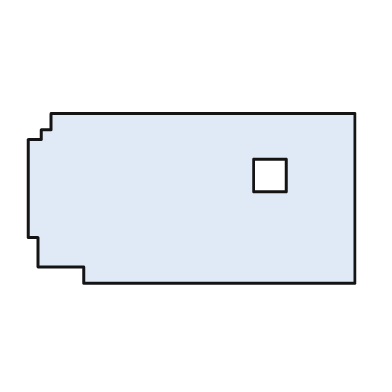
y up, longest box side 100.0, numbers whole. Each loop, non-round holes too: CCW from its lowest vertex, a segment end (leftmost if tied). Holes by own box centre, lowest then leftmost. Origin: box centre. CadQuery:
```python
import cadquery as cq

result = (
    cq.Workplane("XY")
    .moveTo(-33.0, -26.0)
    .lineTo(50.0, -26.0)
    .lineTo(50.0, 26.0)
    .lineTo(-43.0, 26.0)
    .lineTo(-43.0, 21.0)
    .lineTo(-46.0, 21.0)
    .lineTo(-46.0, 18.0)
    .lineTo(-50.0, 18.0)
    .lineTo(-50.0, -12.0)
    .lineTo(-47.0, -12.0)
    .lineTo(-47.0, -21.0)
    .lineTo(-33.0, -21.0)
    .close()
    .moveTo(19.0, 2.0)
    .lineTo(29.0, 2.0)
    .lineTo(29.0, 12.0)
    .lineTo(19.0, 12.0)
    .close()
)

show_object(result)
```